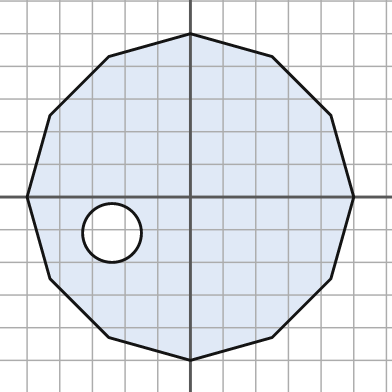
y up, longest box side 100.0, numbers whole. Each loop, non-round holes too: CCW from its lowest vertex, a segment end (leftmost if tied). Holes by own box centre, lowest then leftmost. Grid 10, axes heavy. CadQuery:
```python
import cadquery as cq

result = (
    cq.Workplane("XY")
    .moveTo(0.0, -50.0)
    .lineTo(25.0, -43.0)
    .lineTo(43.0, -25.0)
    .lineTo(50.0, 0.0)
    .lineTo(43.0, 25.0)
    .lineTo(25.0, 43.0)
    .lineTo(0.0, 50.0)
    .lineTo(-25.0, 43.0)
    .lineTo(-43.0, 25.0)
    .lineTo(-50.0, 0.0)
    .lineTo(-43.0, -25.0)
    .lineTo(-25.0, -43.0)
    .close()
    .moveTo(-24.0, -11.0)
    .circle(9.0)
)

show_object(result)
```